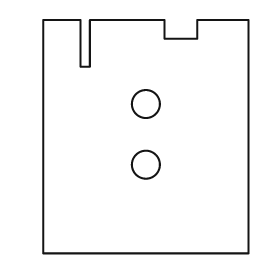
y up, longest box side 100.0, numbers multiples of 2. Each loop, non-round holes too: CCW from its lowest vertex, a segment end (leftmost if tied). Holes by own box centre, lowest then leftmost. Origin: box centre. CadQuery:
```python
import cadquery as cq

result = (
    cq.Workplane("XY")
    .moveTo(-44.0, -50.0)
    .lineTo(44.0, -50.0)
    .lineTo(44.0, 50.0)
    .lineTo(22.0, 50.0)
    .lineTo(22.0, 42.0)
    .lineTo(8.0, 42.0)
    .lineTo(8.0, 50.0)
    .lineTo(-24.0, 50.0)
    .lineTo(-24.0, 30.0)
    .lineTo(-28.0, 30.0)
    .lineTo(-28.0, 50.0)
    .lineTo(-44.0, 50.0)
    .close()
    .moveTo(0.0, -12.0)
    .circle(6.0)
    .moveTo(0.0, 14.0)
    .circle(6.0)
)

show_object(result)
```